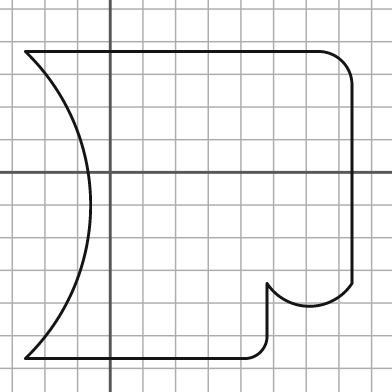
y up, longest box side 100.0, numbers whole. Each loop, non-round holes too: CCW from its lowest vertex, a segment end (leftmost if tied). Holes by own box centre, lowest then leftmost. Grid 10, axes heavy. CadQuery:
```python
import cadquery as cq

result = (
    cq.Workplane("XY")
    .moveTo(-26.0, -57.0)
    .lineTo(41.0, -57.0)
    .threePointArc((46.0, -55.0), (48.0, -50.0))
    .lineTo(48.0, -34.0)
    .threePointArc((61.0, -41.0), (74.0, -34.0))
    .lineTo(74.0, 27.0)
    .threePointArc((71.0, 34.0), (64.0, 37.0))
    .lineTo(-26.0, 37.0)
    .threePointArc((-6.0, -10.0), (-26.0, -57.0))
    .close()
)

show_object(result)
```